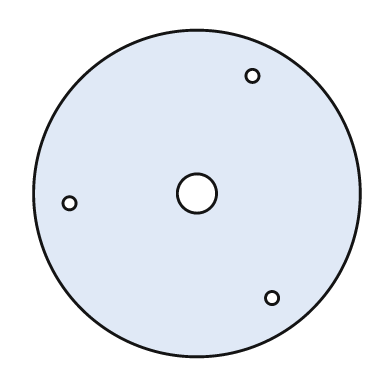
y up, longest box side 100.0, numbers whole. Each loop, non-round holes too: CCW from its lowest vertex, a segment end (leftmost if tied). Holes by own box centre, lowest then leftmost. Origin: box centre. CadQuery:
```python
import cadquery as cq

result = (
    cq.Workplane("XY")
    .moveTo(0.0, 0.0)
    .circle(50.0)
    .moveTo(23.0, -32.0)
    .circle(2.0)
    .moveTo(-39.0, -3.0)
    .circle(2.0)
    .moveTo(0.0, 0.0)
    .circle(6.0)
    .moveTo(17.0, 36.0)
    .circle(2.0)
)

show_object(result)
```